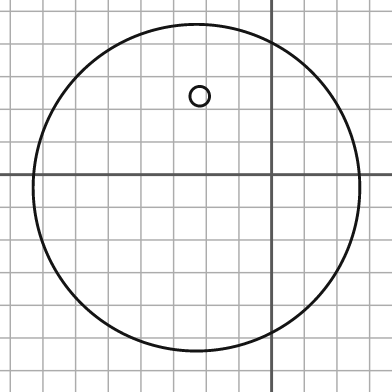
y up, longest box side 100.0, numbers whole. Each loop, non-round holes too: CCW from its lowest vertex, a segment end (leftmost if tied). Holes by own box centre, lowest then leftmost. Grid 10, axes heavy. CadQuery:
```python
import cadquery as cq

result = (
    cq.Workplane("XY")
    .moveTo(-23.0, -4.0)
    .circle(50.0)
    .moveTo(-22.0, 24.0)
    .circle(3.0)
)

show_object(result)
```